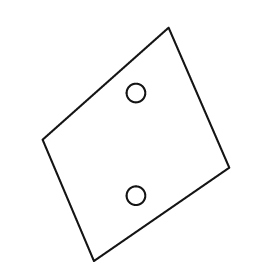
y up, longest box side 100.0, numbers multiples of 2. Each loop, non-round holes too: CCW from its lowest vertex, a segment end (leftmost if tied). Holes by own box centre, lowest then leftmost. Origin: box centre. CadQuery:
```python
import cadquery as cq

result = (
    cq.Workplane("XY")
    .moveTo(-18.0, -50.0)
    .lineTo(40.0, -10.0)
    .lineTo(14.0, 50.0)
    .lineTo(-40.0, 2.0)
    .close()
    .moveTo(0.0, -22.0)
    .circle(4.0)
    .moveTo(0.0, 22.0)
    .circle(4.0)
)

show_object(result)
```